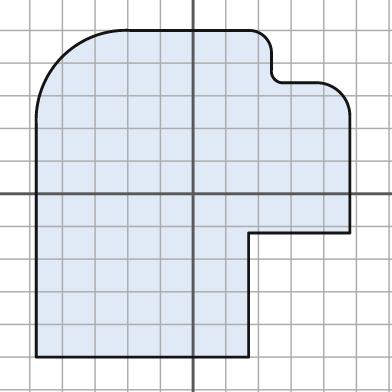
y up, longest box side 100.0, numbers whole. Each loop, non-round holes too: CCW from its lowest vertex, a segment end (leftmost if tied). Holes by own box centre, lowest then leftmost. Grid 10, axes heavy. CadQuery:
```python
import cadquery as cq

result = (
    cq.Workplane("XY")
    .moveTo(-48.0, -50.0)
    .lineTo(17.0, -50.0)
    .lineTo(17.0, -12.0)
    .lineTo(48.0, -12.0)
    .lineTo(48.0, 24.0)
    .threePointArc((45.0, 31.0), (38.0, 34.0))
    .lineTo(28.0, 34.0)
    .threePointArc((25.0, 35.0), (24.0, 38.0))
    .lineTo(24.0, 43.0)
    .threePointArc((22.0, 48.0), (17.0, 50.0))
    .lineTo(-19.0, 50.0)
    .threePointArc((-40.0, 42.0), (-48.0, 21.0))
    .close()
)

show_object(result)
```